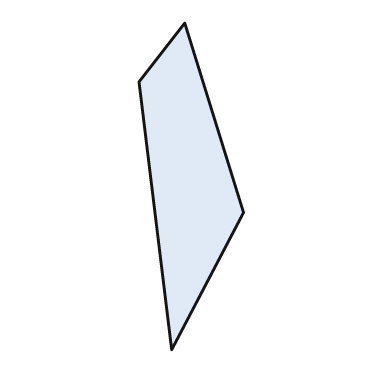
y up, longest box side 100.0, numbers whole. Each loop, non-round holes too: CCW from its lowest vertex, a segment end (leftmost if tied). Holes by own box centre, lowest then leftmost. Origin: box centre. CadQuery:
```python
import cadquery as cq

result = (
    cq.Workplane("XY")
    .moveTo(-6.0, -50.0)
    .lineTo(16.0, -8.0)
    .lineTo(-2.0, 50.0)
    .lineTo(-16.0, 32.0)
    .close()
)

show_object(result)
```